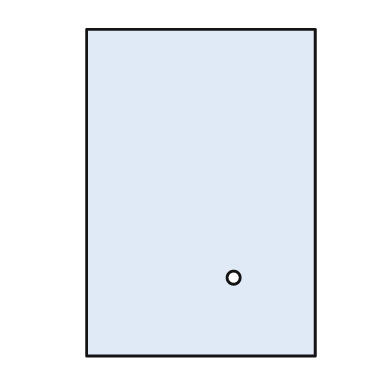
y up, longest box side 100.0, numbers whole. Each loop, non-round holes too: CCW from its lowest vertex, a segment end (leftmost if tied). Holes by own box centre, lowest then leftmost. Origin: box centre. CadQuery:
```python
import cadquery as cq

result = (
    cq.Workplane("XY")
    .moveTo(-35.0, -50.0)
    .lineTo(35.0, -50.0)
    .lineTo(35.0, 50.0)
    .lineTo(-35.0, 50.0)
    .close()
    .moveTo(10.0, -26.0)
    .circle(2.0)
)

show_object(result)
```